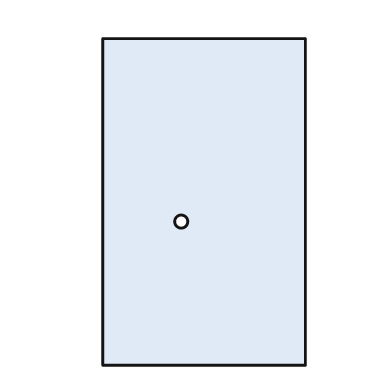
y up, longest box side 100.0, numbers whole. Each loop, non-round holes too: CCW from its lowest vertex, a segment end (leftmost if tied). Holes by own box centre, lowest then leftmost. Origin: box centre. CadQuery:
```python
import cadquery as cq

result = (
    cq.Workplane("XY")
    .moveTo(-31.0, -50.0)
    .lineTo(31.0, -50.0)
    .lineTo(31.0, 50.0)
    .lineTo(-31.0, 50.0)
    .close()
    .moveTo(-7.0, -6.0)
    .circle(2.0)
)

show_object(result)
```